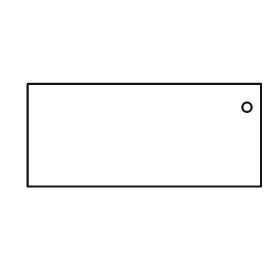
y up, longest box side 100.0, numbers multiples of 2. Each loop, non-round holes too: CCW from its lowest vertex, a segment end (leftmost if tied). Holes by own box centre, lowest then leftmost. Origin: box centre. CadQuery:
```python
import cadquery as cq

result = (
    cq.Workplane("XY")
    .moveTo(-50.0, -22.0)
    .lineTo(50.0, -22.0)
    .lineTo(50.0, 22.0)
    .lineTo(-50.0, 22.0)
    .close()
    .moveTo(44.0, 12.0)
    .circle(2.0)
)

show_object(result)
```